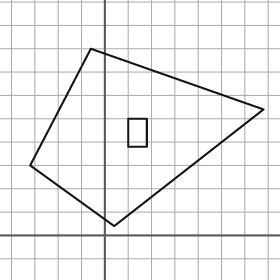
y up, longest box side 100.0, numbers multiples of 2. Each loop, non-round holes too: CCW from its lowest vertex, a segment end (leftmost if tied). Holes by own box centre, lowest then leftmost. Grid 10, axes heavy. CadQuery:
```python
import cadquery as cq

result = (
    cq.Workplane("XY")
    .moveTo(4.0, 4.0)
    .lineTo(68.0, 54.0)
    .lineTo(-6.0, 80.0)
    .lineTo(-32.0, 30.0)
    .close()
    .moveTo(10.0, 38.0)
    .lineTo(18.0, 38.0)
    .lineTo(18.0, 50.0)
    .lineTo(10.0, 50.0)
    .close()
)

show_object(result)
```